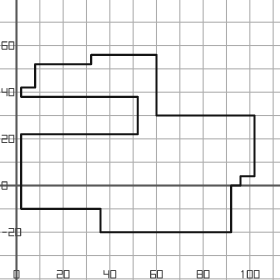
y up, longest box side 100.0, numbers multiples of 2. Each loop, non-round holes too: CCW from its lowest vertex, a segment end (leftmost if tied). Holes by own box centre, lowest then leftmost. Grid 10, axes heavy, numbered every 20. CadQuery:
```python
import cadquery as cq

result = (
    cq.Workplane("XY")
    .moveTo(36.0, -20.0)
    .lineTo(92.0, -20.0)
    .lineTo(92.0, 0.0)
    .lineTo(96.0, 0.0)
    .lineTo(96.0, 4.0)
    .lineTo(102.0, 4.0)
    .lineTo(102.0, 30.0)
    .lineTo(60.0, 30.0)
    .lineTo(60.0, 56.0)
    .lineTo(32.0, 56.0)
    .lineTo(32.0, 52.0)
    .lineTo(8.0, 52.0)
    .lineTo(8.0, 42.0)
    .lineTo(2.0, 42.0)
    .lineTo(2.0, 38.0)
    .lineTo(52.0, 38.0)
    .lineTo(52.0, 22.0)
    .lineTo(2.0, 22.0)
    .lineTo(2.0, -10.0)
    .lineTo(36.0, -10.0)
    .close()
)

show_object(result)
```